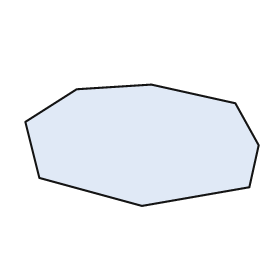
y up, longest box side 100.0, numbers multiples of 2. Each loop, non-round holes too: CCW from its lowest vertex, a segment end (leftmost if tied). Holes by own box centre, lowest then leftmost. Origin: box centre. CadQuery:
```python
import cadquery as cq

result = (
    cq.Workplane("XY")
    .moveTo(0.0, -26.0)
    .lineTo(46.0, -18.0)
    .lineTo(50.0, 0.0)
    .lineTo(40.0, 18.0)
    .lineTo(4.0, 26.0)
    .lineTo(-28.0, 24.0)
    .lineTo(-50.0, 10.0)
    .lineTo(-44.0, -14.0)
    .close()
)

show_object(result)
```